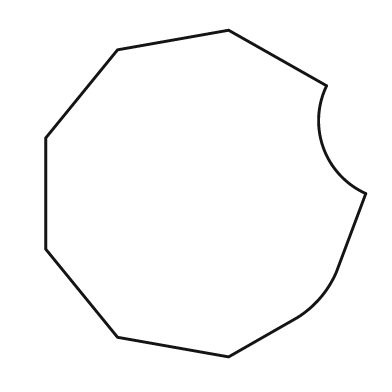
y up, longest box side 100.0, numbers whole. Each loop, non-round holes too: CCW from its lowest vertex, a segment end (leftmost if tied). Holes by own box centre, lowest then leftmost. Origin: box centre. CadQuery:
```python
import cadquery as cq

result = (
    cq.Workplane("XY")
    .moveTo(7.0, -50.0)
    .lineTo(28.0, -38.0)
    .threePointArc((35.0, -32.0), (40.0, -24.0))
    .lineTo(49.0, 0.0)
    .threePointArc((36.0, 14.0), (37.0, 33.0))
    .lineTo(7.0, 50.0)
    .lineTo(-27.0, 44.0)
    .lineTo(-49.0, 17.0)
    .lineTo(-49.0, -17.0)
    .lineTo(-27.0, -44.0)
    .close()
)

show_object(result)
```